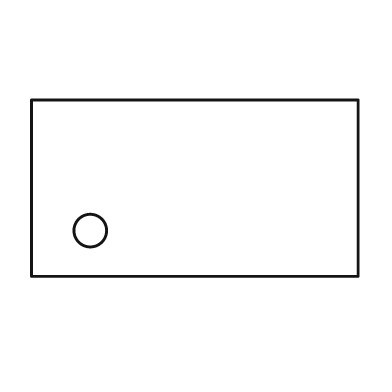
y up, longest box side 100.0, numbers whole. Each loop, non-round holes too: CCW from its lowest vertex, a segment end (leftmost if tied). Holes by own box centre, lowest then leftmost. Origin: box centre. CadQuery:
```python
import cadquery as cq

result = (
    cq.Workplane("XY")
    .moveTo(-50.0, -27.0)
    .lineTo(50.0, -27.0)
    .lineTo(50.0, 27.0)
    .lineTo(-50.0, 27.0)
    .close()
    .moveTo(-32.0, -13.0)
    .circle(5.0)
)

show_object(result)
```